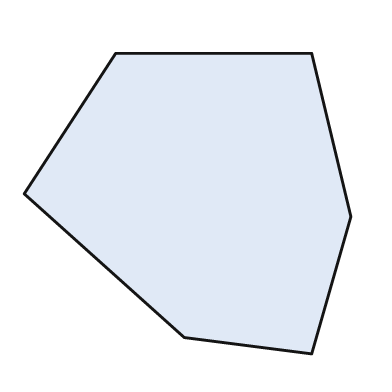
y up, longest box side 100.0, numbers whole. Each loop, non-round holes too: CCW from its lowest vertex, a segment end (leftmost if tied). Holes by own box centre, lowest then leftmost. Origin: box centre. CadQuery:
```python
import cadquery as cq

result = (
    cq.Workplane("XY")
    .moveTo(38.0, -46.0)
    .lineTo(50.0, -4.0)
    .lineTo(38.0, 46.0)
    .lineTo(-22.0, 46.0)
    .lineTo(-50.0, 3.0)
    .lineTo(-1.0, -41.0)
    .close()
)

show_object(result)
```